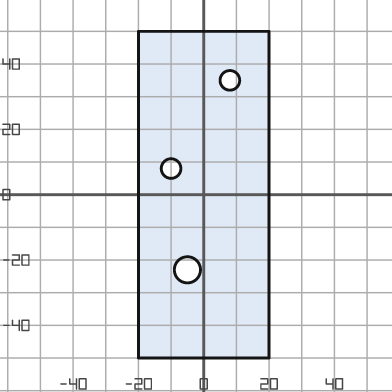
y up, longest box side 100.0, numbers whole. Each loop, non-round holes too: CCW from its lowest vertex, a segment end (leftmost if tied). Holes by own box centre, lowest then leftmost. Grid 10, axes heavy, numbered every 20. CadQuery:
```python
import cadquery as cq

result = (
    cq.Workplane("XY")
    .moveTo(-20.0, -50.0)
    .lineTo(20.0, -50.0)
    .lineTo(20.0, 50.0)
    .lineTo(-20.0, 50.0)
    .close()
    .moveTo(-5.0, -23.0)
    .circle(4.0)
    .moveTo(-10.0, 8.0)
    .circle(3.0)
    .moveTo(8.0, 35.0)
    .circle(3.0)
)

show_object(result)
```